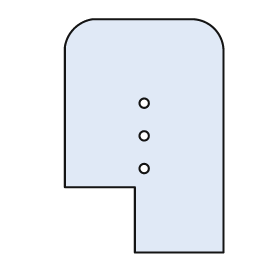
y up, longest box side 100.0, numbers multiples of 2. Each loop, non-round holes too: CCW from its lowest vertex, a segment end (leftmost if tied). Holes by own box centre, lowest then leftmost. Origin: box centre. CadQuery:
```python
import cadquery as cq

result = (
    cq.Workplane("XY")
    .moveTo(-4.0, -50.0)
    .lineTo(34.0, -50.0)
    .lineTo(34.0, 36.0)
    .threePointArc((30.0, 46.0), (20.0, 50.0))
    .lineTo(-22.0, 50.0)
    .threePointArc((-30.0, 46.0), (-34.0, 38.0))
    .lineTo(-34.0, -22.0)
    .lineTo(-4.0, -22.0)
    .close()
    .moveTo(0.0, -14.0)
    .circle(2.0)
    .moveTo(0.0, 0.0)
    .circle(2.0)
    .moveTo(0.0, 14.0)
    .circle(2.0)
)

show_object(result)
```